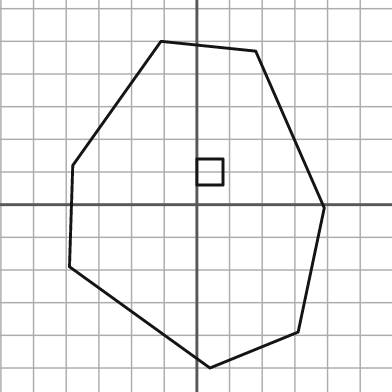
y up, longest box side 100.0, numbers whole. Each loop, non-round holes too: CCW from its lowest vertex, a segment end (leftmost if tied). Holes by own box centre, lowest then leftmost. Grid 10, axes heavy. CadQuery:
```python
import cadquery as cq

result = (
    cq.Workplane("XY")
    .moveTo(4.0, -50.0)
    .lineTo(31.0, -39.0)
    .lineTo(39.0, -1.0)
    .lineTo(18.0, 47.0)
    .lineTo(-11.0, 50.0)
    .lineTo(-38.0, 12.0)
    .lineTo(-39.0, -19.0)
    .close()
    .moveTo(0.0, 6.0)
    .lineTo(8.0, 6.0)
    .lineTo(8.0, 14.0)
    .lineTo(0.0, 14.0)
    .close()
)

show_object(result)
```